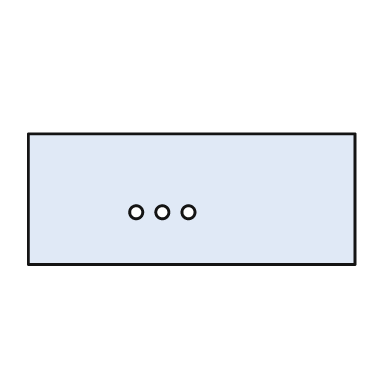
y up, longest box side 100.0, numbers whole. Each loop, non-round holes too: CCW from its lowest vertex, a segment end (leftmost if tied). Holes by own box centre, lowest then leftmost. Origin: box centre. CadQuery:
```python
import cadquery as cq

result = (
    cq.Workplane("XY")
    .moveTo(-50.0, -20.0)
    .lineTo(50.0, -20.0)
    .lineTo(50.0, 20.0)
    .lineTo(-50.0, 20.0)
    .close()
    .moveTo(-17.0, -4.0)
    .circle(2.0)
    .moveTo(-9.0, -4.0)
    .circle(2.0)
    .moveTo(-1.0, -4.0)
    .circle(2.0)
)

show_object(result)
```